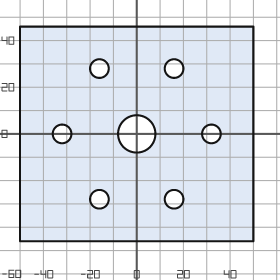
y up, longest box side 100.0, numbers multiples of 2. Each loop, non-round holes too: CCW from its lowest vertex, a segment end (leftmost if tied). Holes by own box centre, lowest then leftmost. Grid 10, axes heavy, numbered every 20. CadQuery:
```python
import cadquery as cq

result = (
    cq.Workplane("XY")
    .moveTo(-50.0, -46.0)
    .lineTo(50.0, -46.0)
    .lineTo(50.0, 46.0)
    .lineTo(-50.0, 46.0)
    .close()
    .moveTo(-16.0, -28.0)
    .circle(4.0)
    .moveTo(16.0, -28.0)
    .circle(4.0)
    .moveTo(-32.0, 0.0)
    .circle(4.0)
    .moveTo(0.0, 0.0)
    .circle(8.0)
    .moveTo(32.0, 0.0)
    .circle(4.0)
    .moveTo(-16.0, 28.0)
    .circle(4.0)
    .moveTo(16.0, 28.0)
    .circle(4.0)
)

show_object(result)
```